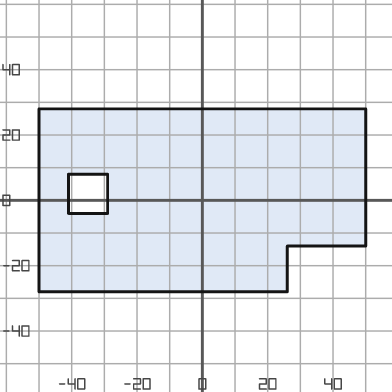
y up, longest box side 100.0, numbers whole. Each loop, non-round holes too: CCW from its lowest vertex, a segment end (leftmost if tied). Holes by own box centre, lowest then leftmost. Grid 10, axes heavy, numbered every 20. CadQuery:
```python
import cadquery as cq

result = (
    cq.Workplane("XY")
    .moveTo(-50.0, -28.0)
    .lineTo(26.0, -28.0)
    .lineTo(26.0, -14.0)
    .lineTo(50.0, -14.0)
    .lineTo(50.0, 28.0)
    .lineTo(-50.0, 28.0)
    .close()
    .moveTo(-41.0, -4.0)
    .lineTo(-29.0, -4.0)
    .lineTo(-29.0, 8.0)
    .lineTo(-41.0, 8.0)
    .close()
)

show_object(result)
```